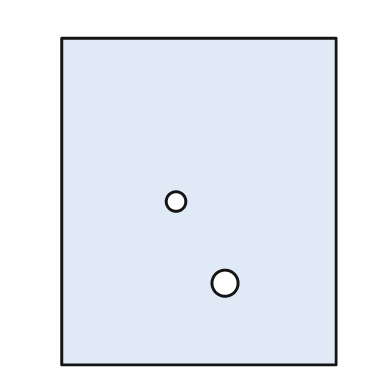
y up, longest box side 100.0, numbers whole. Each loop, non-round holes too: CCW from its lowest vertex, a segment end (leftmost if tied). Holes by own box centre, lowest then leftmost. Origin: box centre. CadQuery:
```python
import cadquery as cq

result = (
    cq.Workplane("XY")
    .moveTo(-42.0, -50.0)
    .lineTo(42.0, -50.0)
    .lineTo(42.0, 50.0)
    .lineTo(-42.0, 50.0)
    .close()
    .moveTo(8.0, -25.0)
    .circle(4.0)
    .moveTo(-7.0, 0.0)
    .circle(3.0)
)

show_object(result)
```